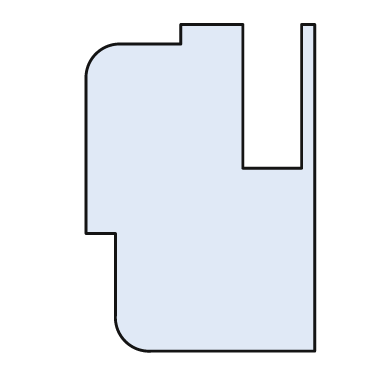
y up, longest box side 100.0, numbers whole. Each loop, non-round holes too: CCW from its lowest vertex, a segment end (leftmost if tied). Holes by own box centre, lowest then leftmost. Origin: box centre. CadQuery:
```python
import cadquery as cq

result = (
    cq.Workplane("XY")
    .moveTo(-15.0, -50.0)
    .lineTo(35.0, -50.0)
    .lineTo(35.0, 50.0)
    .lineTo(31.0, 50.0)
    .lineTo(31.0, 6.0)
    .lineTo(13.0, 6.0)
    .lineTo(13.0, 50.0)
    .lineTo(-6.0, 50.0)
    .lineTo(-6.0, 44.0)
    .lineTo(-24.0, 44.0)
    .threePointArc((-32.0, 41.0), (-35.0, 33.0))
    .lineTo(-35.0, -14.0)
    .lineTo(-26.0, -14.0)
    .lineTo(-26.0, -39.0)
    .threePointArc((-23.0, -47.0), (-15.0, -50.0))
    .close()
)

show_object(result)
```